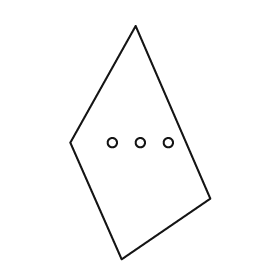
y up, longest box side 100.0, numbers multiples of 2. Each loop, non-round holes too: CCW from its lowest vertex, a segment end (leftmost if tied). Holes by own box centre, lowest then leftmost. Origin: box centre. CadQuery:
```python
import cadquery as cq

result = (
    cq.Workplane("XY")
    .moveTo(-8.0, -50.0)
    .lineTo(30.0, -24.0)
    .lineTo(-2.0, 50.0)
    .lineTo(-30.0, 0.0)
    .close()
    .moveTo(-12.0, 0.0)
    .circle(2.0)
    .moveTo(0.0, 0.0)
    .circle(2.0)
    .moveTo(12.0, 0.0)
    .circle(2.0)
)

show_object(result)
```